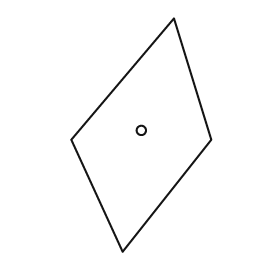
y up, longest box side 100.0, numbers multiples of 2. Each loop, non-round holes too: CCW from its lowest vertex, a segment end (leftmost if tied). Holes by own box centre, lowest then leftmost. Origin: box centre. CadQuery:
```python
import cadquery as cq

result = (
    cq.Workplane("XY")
    .moveTo(-8.0, -50.0)
    .lineTo(30.0, -2.0)
    .lineTo(14.0, 50.0)
    .lineTo(-30.0, -2.0)
    .close()
    .moveTo(0.0, 2.0)
    .circle(2.0)
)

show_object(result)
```